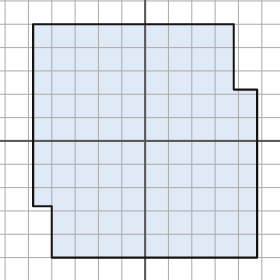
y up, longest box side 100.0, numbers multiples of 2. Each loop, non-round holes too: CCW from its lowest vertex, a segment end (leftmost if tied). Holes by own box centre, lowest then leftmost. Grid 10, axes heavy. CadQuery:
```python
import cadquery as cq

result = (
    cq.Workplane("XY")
    .moveTo(-40.0, -50.0)
    .lineTo(48.0, -50.0)
    .lineTo(48.0, 22.0)
    .lineTo(38.0, 22.0)
    .lineTo(38.0, 50.0)
    .lineTo(-48.0, 50.0)
    .lineTo(-48.0, -28.0)
    .lineTo(-40.0, -28.0)
    .close()
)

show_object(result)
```